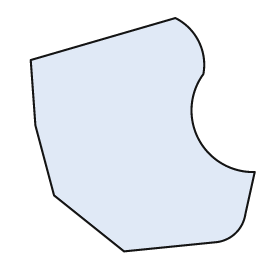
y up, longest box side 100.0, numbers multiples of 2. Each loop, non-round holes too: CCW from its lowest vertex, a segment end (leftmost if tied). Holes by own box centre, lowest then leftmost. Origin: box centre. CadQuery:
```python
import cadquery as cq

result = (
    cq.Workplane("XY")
    .moveTo(-8.0, -50.0)
    .lineTo(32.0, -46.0)
    .threePointArc((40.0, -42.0), (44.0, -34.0))
    .lineTo(48.0, -16.0)
    .threePointArc((24.0, -2.0), (26.0, 26.0))
    .threePointArc((24.0, 40.0), (14.0, 50.0))
    .lineTo(-48.0, 32.0)
    .lineTo(-46.0, 4.0)
    .lineTo(-38.0, -26.0)
    .close()
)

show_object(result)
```